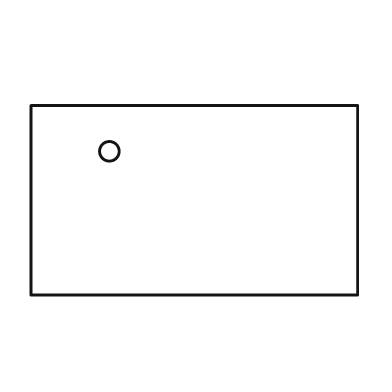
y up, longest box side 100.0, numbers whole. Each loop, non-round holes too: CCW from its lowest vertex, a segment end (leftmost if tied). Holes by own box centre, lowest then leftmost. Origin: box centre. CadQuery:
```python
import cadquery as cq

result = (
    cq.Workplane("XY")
    .moveTo(-50.0, -29.0)
    .lineTo(50.0, -29.0)
    .lineTo(50.0, 29.0)
    .lineTo(-50.0, 29.0)
    .close()
    .moveTo(-26.0, 15.0)
    .circle(3.0)
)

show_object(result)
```